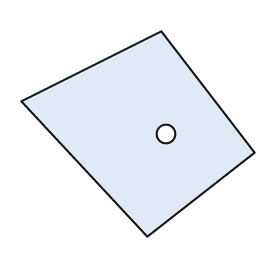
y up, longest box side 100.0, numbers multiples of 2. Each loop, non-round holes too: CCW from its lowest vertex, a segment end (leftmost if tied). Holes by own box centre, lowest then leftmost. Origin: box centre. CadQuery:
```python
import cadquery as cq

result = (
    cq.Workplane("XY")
    .moveTo(4.0, -44.0)
    .lineTo(50.0, -8.0)
    .lineTo(10.0, 44.0)
    .lineTo(-50.0, 14.0)
    .close()
    .moveTo(12.0, 0.0)
    .circle(4.0)
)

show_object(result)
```